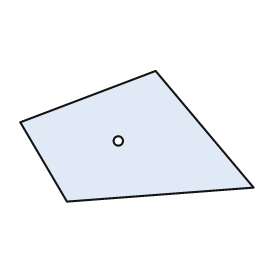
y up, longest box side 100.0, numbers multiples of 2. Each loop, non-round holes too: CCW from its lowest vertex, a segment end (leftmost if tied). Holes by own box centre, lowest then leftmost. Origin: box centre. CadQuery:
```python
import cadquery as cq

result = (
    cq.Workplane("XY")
    .moveTo(-30.0, -28.0)
    .lineTo(50.0, -22.0)
    .lineTo(8.0, 28.0)
    .lineTo(-50.0, 6.0)
    .close()
    .moveTo(-8.0, -2.0)
    .circle(2.0)
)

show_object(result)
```